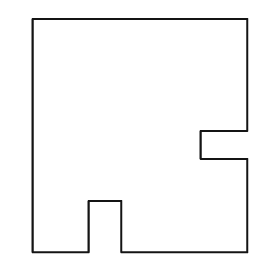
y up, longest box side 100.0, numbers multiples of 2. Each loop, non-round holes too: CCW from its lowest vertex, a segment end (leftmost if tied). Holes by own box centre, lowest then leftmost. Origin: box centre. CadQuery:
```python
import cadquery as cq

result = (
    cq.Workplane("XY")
    .moveTo(-46.0, -50.0)
    .lineTo(-22.0, -50.0)
    .lineTo(-22.0, -28.0)
    .lineTo(-8.0, -28.0)
    .lineTo(-8.0, -50.0)
    .lineTo(46.0, -50.0)
    .lineTo(46.0, -10.0)
    .lineTo(26.0, -10.0)
    .lineTo(26.0, 2.0)
    .lineTo(46.0, 2.0)
    .lineTo(46.0, 50.0)
    .lineTo(-46.0, 50.0)
    .close()
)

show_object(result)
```